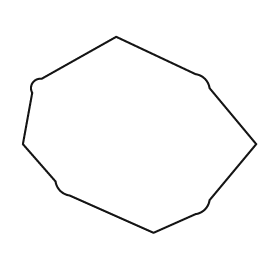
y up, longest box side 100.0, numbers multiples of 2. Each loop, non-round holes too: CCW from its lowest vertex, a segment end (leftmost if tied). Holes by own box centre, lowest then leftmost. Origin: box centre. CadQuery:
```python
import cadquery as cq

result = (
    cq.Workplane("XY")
    .moveTo(6.0, -42.0)
    .lineTo(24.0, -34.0)
    .threePointArc((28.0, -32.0), (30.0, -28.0))
    .lineTo(50.0, -4.0)
    .lineTo(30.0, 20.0)
    .threePointArc((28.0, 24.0), (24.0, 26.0))
    .lineTo(-10.0, 42.0)
    .lineTo(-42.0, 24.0)
    .threePointArc((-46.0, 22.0), (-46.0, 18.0))
    .lineTo(-50.0, -4.0)
    .lineTo(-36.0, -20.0)
    .threePointArc((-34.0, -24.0), (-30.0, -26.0))
    .close()
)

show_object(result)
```